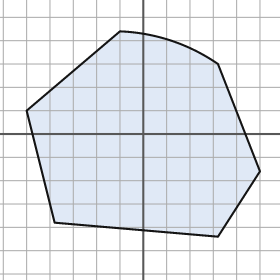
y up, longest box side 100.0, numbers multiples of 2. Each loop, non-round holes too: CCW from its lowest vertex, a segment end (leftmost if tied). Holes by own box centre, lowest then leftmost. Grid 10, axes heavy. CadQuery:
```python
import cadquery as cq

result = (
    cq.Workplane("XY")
    .moveTo(32.0, -44.0)
    .lineTo(50.0, -16.0)
    .lineTo(32.0, 30.0)
    .threePointArc((12.0, 40.0), (-10.0, 44.0))
    .lineTo(-50.0, 10.0)
    .lineTo(-38.0, -38.0)
    .close()
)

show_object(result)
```